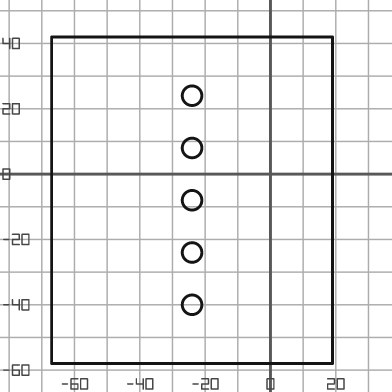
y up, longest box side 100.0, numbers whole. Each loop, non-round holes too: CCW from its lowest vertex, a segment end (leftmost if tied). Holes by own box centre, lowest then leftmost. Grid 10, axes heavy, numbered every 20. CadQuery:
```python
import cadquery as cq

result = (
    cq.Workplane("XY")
    .moveTo(-67.0, -58.0)
    .lineTo(19.0, -58.0)
    .lineTo(19.0, 42.0)
    .lineTo(-67.0, 42.0)
    .close()
    .moveTo(-24.0, -40.0)
    .circle(3.0)
    .moveTo(-24.0, -24.0)
    .circle(3.0)
    .moveTo(-24.0, -8.0)
    .circle(3.0)
    .moveTo(-24.0, 8.0)
    .circle(3.0)
    .moveTo(-24.0, 24.0)
    .circle(3.0)
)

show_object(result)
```